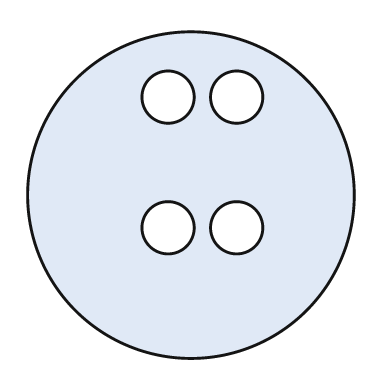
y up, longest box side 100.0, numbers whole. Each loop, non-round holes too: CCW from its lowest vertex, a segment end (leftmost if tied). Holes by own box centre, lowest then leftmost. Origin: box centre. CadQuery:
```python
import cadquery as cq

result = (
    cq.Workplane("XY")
    .moveTo(0.0, 0.0)
    .circle(50.0)
    .moveTo(-7.0, -10.0)
    .circle(8.0)
    .moveTo(14.0, -10.0)
    .circle(8.0)
    .moveTo(-7.0, 30.0)
    .circle(8.0)
    .moveTo(14.0, 30.0)
    .circle(8.0)
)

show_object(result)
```